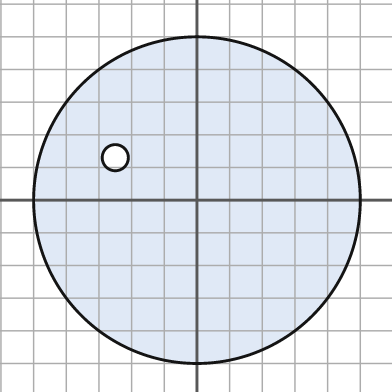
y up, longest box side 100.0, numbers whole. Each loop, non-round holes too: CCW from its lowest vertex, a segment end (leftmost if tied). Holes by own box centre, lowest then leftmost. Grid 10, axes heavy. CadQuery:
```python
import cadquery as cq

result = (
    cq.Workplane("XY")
    .moveTo(0.0, 0.0)
    .circle(50.0)
    .moveTo(-25.0, 13.0)
    .circle(4.0)
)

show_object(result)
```